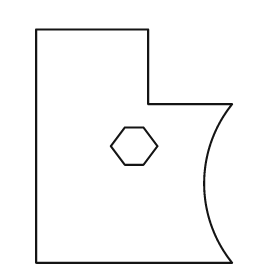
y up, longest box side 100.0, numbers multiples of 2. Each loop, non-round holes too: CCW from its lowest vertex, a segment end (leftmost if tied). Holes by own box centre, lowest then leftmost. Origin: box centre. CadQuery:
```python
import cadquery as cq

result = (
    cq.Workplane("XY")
    .moveTo(-42.0, -50.0)
    .lineTo(42.0, -50.0)
    .threePointArc((30.0, -16.0), (42.0, 18.0))
    .lineTo(6.0, 18.0)
    .lineTo(6.0, 50.0)
    .lineTo(-42.0, 50.0)
    .close()
    .moveTo(-4.0, -8.0)
    .lineTo(4.0, -8.0)
    .lineTo(10.0, 0.0)
    .lineTo(4.0, 8.0)
    .lineTo(-4.0, 8.0)
    .lineTo(-10.0, 0.0)
    .close()
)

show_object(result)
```